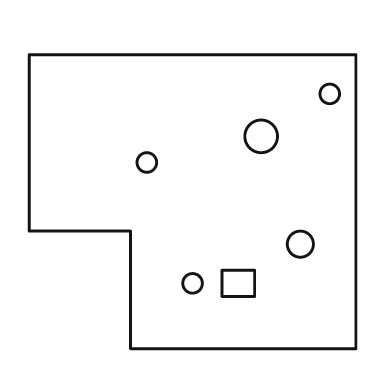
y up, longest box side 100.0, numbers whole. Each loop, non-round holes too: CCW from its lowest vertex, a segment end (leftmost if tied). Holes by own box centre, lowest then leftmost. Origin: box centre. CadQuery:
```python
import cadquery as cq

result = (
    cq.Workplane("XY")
    .moveTo(-19.0, -45.0)
    .lineTo(50.0, -45.0)
    .lineTo(50.0, 45.0)
    .lineTo(-50.0, 45.0)
    .lineTo(-50.0, -9.0)
    .lineTo(-19.0, -9.0)
    .close()
    .moveTo(0.0, -25.0)
    .circle(3.0)
    .moveTo(9.0, -29.0)
    .lineTo(19.0, -29.0)
    .lineTo(19.0, -21.0)
    .lineTo(9.0, -21.0)
    .close()
    .moveTo(33.0, -13.0)
    .circle(4.0)
    .moveTo(-14.0, 12.0)
    .circle(3.0)
    .moveTo(21.0, 20.0)
    .circle(5.0)
    .moveTo(42.0, 33.0)
    .circle(3.0)
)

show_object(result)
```